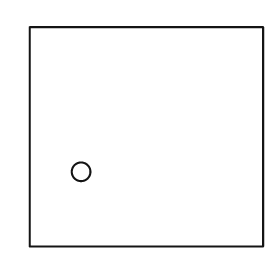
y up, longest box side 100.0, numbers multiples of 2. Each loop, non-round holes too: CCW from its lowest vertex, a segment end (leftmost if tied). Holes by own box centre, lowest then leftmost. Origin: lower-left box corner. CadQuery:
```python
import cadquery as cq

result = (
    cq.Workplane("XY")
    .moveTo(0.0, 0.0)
    .lineTo(100.0, 0.0)
    .lineTo(100.0, 94.0)
    .lineTo(0.0, 94.0)
    .close()
    .moveTo(22.0, 32.0)
    .circle(4.0)
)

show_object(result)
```